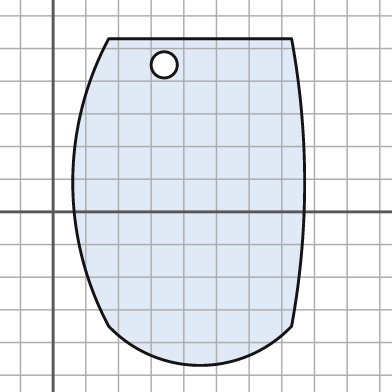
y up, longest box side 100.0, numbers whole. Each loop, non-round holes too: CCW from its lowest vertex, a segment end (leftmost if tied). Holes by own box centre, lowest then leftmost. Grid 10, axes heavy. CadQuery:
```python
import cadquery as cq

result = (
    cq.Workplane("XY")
    .moveTo(17.0, -35.0)
    .threePointArc((45.0, -47.0), (73.0, -35.0))
    .threePointArc((77.0, 9.0), (73.0, 53.0))
    .lineTo(17.0, 53.0)
    .threePointArc((6.0, 9.0), (17.0, -35.0))
    .close()
    .moveTo(34.0, 45.0)
    .circle(4.0)
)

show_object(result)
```